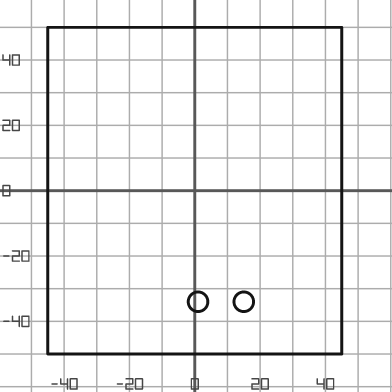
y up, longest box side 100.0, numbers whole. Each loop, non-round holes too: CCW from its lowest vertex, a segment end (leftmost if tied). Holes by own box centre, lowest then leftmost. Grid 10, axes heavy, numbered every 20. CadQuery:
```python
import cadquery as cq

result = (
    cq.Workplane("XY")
    .moveTo(-45.0, -50.0)
    .lineTo(45.0, -50.0)
    .lineTo(45.0, 50.0)
    .lineTo(-45.0, 50.0)
    .close()
    .moveTo(1.0, -34.0)
    .circle(3.0)
    .moveTo(15.0, -34.0)
    .circle(3.0)
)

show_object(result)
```